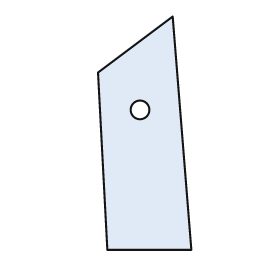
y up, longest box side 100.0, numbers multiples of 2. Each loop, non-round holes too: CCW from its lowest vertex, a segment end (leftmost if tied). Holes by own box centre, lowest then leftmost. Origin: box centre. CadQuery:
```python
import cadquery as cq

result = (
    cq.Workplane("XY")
    .moveTo(-16.0, -50.0)
    .lineTo(20.0, -50.0)
    .lineTo(12.0, 50.0)
    .lineTo(-20.0, 26.0)
    .close()
    .moveTo(-2.0, 10.0)
    .circle(4.0)
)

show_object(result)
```